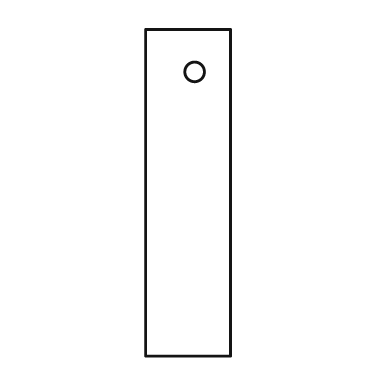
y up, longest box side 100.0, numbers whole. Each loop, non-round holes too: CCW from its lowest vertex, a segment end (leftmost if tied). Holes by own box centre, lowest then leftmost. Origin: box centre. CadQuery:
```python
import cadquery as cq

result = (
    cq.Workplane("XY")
    .moveTo(-13.0, -50.0)
    .lineTo(13.0, -50.0)
    .lineTo(13.0, 50.0)
    .lineTo(-13.0, 50.0)
    .close()
    .moveTo(2.0, 37.0)
    .circle(3.0)
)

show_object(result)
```